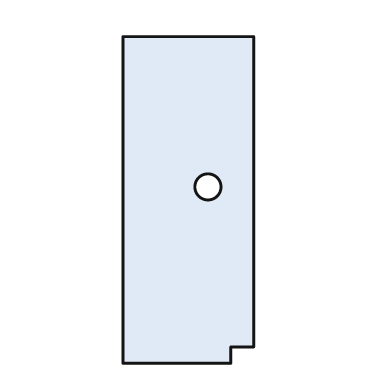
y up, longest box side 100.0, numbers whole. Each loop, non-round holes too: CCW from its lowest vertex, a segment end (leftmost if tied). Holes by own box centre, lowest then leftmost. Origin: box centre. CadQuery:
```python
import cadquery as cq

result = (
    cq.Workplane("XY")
    .moveTo(-20.0, -50.0)
    .lineTo(13.0, -50.0)
    .lineTo(13.0, -45.0)
    .lineTo(20.0, -45.0)
    .lineTo(20.0, 50.0)
    .lineTo(-20.0, 50.0)
    .close()
    .moveTo(6.0, 4.0)
    .circle(4.0)
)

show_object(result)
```